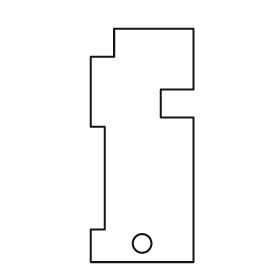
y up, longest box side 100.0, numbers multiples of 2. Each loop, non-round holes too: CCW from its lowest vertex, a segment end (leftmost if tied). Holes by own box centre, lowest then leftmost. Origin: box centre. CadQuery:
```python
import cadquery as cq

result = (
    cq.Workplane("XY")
    .moveTo(-22.0, -50.0)
    .lineTo(22.0, -50.0)
    .lineTo(22.0, 12.0)
    .lineTo(8.0, 12.0)
    .lineTo(8.0, 24.0)
    .lineTo(22.0, 24.0)
    .lineTo(22.0, 50.0)
    .lineTo(-12.0, 50.0)
    .lineTo(-12.0, 38.0)
    .lineTo(-22.0, 38.0)
    .lineTo(-22.0, 8.0)
    .lineTo(-16.0, 8.0)
    .lineTo(-16.0, -36.0)
    .lineTo(-22.0, -36.0)
    .close()
    .moveTo(0.0, -42.0)
    .circle(4.0)
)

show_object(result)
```